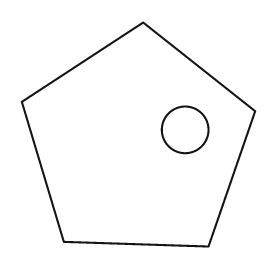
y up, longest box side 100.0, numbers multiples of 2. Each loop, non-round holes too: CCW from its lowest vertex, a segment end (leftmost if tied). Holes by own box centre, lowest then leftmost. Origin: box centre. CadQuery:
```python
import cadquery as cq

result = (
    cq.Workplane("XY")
    .moveTo(30.0, -48.0)
    .lineTo(50.0, 10.0)
    .lineTo(2.0, 48.0)
    .lineTo(-50.0, 14.0)
    .lineTo(-32.0, -46.0)
    .close()
    .moveTo(20.0, 2.0)
    .circle(10.0)
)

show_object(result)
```